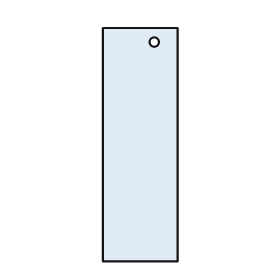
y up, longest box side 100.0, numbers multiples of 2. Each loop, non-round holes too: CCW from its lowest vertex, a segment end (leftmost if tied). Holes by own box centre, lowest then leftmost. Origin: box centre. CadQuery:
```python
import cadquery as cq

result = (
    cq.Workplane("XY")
    .moveTo(-16.0, -50.0)
    .lineTo(16.0, -50.0)
    .lineTo(16.0, 50.0)
    .lineTo(-16.0, 50.0)
    .close()
    .moveTo(6.0, 44.0)
    .circle(2.0)
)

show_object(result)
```